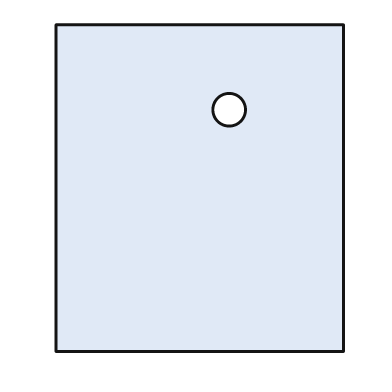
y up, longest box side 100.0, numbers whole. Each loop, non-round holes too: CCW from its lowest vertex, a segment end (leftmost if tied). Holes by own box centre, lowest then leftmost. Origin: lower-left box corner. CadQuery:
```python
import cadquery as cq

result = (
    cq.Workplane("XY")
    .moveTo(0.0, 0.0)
    .lineTo(88.0, 0.0)
    .lineTo(88.0, 100.0)
    .lineTo(0.0, 100.0)
    .close()
    .moveTo(53.0, 74.0)
    .circle(5.0)
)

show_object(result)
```